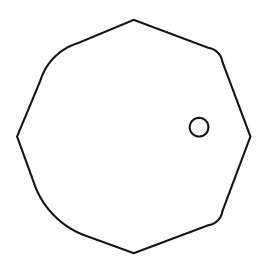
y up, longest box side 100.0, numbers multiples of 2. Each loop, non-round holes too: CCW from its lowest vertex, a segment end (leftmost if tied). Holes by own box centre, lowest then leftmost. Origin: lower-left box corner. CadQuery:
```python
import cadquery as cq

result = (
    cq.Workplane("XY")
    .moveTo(50.0, 0.0)
    .lineTo(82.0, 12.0)
    .threePointArc((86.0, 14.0), (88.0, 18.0))
    .lineTo(100.0, 50.0)
    .lineTo(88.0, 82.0)
    .threePointArc((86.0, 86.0), (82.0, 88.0))
    .lineTo(50.0, 100.0)
    .lineTo(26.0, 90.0)
    .threePointArc((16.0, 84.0), (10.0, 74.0))
    .lineTo(0.0, 50.0)
    .lineTo(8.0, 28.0)
    .threePointArc((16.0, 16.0), (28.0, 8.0))
    .close()
    .moveTo(78.0, 54.0)
    .circle(4.0)
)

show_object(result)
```